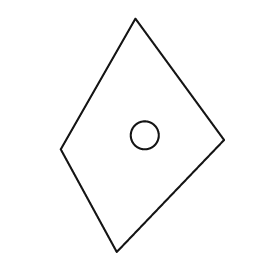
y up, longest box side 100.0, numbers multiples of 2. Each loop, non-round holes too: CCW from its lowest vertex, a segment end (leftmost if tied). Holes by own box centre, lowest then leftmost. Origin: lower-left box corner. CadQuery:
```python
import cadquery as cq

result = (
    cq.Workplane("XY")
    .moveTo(24.0, 0.0)
    .lineTo(70.0, 48.0)
    .lineTo(32.0, 100.0)
    .lineTo(0.0, 44.0)
    .close()
    .moveTo(36.0, 50.0)
    .circle(6.0)
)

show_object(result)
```